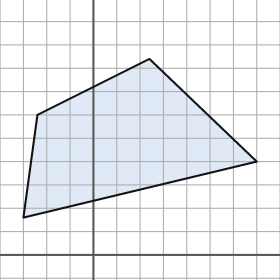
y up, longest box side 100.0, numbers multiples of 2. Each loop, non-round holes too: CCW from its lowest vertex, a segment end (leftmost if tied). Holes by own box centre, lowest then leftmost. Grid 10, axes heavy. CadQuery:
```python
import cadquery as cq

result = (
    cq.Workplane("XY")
    .moveTo(-30.0, 16.0)
    .lineTo(70.0, 40.0)
    .lineTo(24.0, 84.0)
    .lineTo(-24.0, 60.0)
    .close()
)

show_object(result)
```